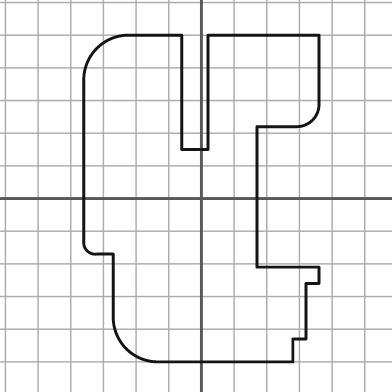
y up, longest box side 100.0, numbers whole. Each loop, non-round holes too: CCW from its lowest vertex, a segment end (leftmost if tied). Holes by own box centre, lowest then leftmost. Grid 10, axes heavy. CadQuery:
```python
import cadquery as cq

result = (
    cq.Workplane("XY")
    .moveTo(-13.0, -50.0)
    .lineTo(28.0, -50.0)
    .lineTo(28.0, -43.0)
    .lineTo(32.0, -43.0)
    .lineTo(32.0, -26.0)
    .lineTo(36.0, -26.0)
    .lineTo(36.0, -21.0)
    .lineTo(17.0, -21.0)
    .lineTo(17.0, 22.0)
    .lineTo(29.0, 22.0)
    .threePointArc((34.0, 24.0), (36.0, 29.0))
    .lineTo(36.0, 50.0)
    .lineTo(2.0, 50.0)
    .lineTo(2.0, 15.0)
    .lineTo(-6.0, 15.0)
    .lineTo(-6.0, 50.0)
    .lineTo(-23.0, 50.0)
    .threePointArc((-32.0, 46.0), (-36.0, 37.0))
    .lineTo(-36.0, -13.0)
    .threePointArc((-35.0, -16.0), (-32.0, -17.0))
    .lineTo(-27.0, -17.0)
    .lineTo(-27.0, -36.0)
    .threePointArc((-23.0, -46.0), (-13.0, -50.0))
    .close()
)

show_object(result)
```